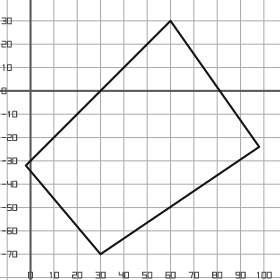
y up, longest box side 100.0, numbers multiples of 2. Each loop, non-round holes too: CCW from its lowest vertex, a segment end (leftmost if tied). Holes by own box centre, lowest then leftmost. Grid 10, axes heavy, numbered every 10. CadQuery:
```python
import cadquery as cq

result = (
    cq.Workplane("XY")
    .moveTo(30.0, -70.0)
    .lineTo(98.0, -24.0)
    .lineTo(60.0, 30.0)
    .lineTo(-2.0, -32.0)
    .close()
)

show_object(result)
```